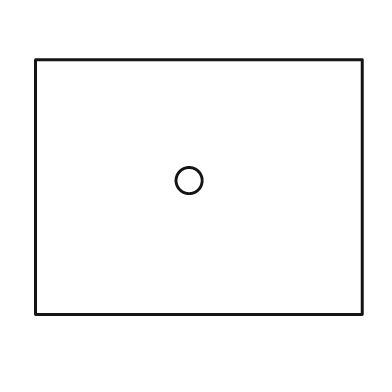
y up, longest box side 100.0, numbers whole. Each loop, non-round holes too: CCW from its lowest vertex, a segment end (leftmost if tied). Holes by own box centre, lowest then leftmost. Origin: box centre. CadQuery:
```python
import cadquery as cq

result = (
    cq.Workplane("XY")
    .moveTo(-50.0, -39.0)
    .lineTo(50.0, -39.0)
    .lineTo(50.0, 39.0)
    .lineTo(-50.0, 39.0)
    .close()
    .moveTo(-3.0, 2.0)
    .circle(4.0)
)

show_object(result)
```